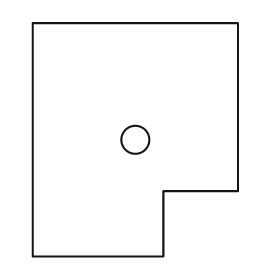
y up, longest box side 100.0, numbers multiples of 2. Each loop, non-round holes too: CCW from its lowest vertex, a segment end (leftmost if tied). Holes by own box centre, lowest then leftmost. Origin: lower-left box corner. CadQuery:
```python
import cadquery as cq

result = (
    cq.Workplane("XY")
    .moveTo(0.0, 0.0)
    .lineTo(56.0, 0.0)
    .lineTo(56.0, 28.0)
    .lineTo(88.0, 28.0)
    .lineTo(88.0, 100.0)
    .lineTo(0.0, 100.0)
    .close()
    .moveTo(44.0, 50.0)
    .circle(6.0)
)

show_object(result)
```